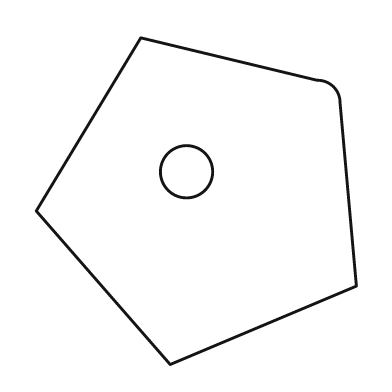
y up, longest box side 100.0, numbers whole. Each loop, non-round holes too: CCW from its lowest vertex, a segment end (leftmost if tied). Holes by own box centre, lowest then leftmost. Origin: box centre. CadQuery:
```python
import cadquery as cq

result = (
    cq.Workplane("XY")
    .moveTo(-8.0, -50.0)
    .lineTo(49.0, -26.0)
    .lineTo(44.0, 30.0)
    .threePointArc((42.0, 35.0), (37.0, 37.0))
    .lineTo(-17.0, 50.0)
    .lineTo(-49.0, -3.0)
    .close()
    .moveTo(-3.0, 9.0)
    .circle(8.0)
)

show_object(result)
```